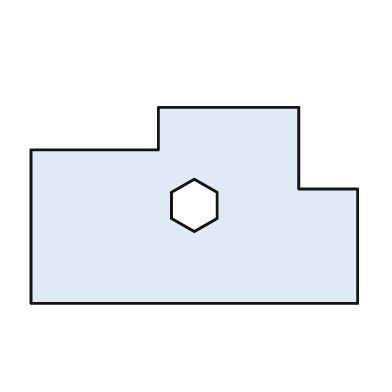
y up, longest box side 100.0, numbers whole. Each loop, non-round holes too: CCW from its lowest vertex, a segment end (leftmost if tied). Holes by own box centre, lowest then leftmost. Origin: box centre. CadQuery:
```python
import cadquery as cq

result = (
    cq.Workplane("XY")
    .moveTo(-50.0, -30.0)
    .lineTo(50.0, -30.0)
    .lineTo(50.0, 5.0)
    .lineTo(32.0, 5.0)
    .lineTo(32.0, 30.0)
    .lineTo(-11.0, 30.0)
    .lineTo(-11.0, 17.0)
    .lineTo(-50.0, 17.0)
    .close()
    .moveTo(0.0, -8.0)
    .lineTo(7.0, -4.0)
    .lineTo(7.0, 4.0)
    .lineTo(0.0, 8.0)
    .lineTo(-7.0, 4.0)
    .lineTo(-7.0, -4.0)
    .close()
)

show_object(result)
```